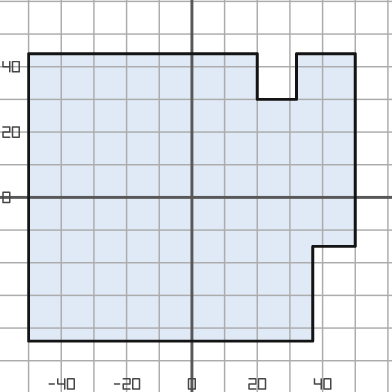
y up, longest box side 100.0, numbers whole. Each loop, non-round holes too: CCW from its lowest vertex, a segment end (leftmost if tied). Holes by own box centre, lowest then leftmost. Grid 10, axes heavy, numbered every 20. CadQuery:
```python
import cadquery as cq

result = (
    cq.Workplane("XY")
    .moveTo(-50.0, -44.0)
    .lineTo(37.0, -44.0)
    .lineTo(37.0, -15.0)
    .lineTo(50.0, -15.0)
    .lineTo(50.0, 44.0)
    .lineTo(32.0, 44.0)
    .lineTo(32.0, 30.0)
    .lineTo(20.0, 30.0)
    .lineTo(20.0, 44.0)
    .lineTo(-50.0, 44.0)
    .close()
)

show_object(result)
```